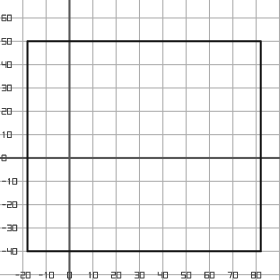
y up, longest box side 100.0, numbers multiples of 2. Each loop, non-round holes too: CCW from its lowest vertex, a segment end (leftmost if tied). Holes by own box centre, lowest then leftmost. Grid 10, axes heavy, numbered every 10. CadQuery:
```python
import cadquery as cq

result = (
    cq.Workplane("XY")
    .moveTo(-18.0, -40.0)
    .lineTo(82.0, -40.0)
    .lineTo(82.0, 50.0)
    .lineTo(-18.0, 50.0)
    .close()
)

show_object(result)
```